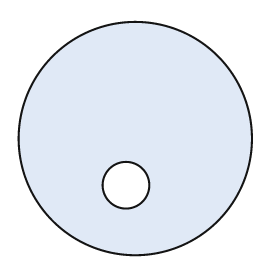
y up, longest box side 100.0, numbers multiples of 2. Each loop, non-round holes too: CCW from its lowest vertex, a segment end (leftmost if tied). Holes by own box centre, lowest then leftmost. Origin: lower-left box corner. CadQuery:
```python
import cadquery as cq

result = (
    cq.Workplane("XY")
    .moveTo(50.0, 50.0)
    .circle(50.0)
    .moveTo(46.0, 30.0)
    .circle(10.0)
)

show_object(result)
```